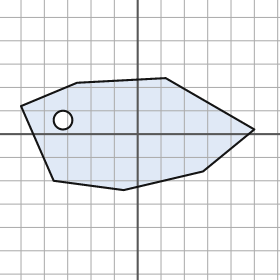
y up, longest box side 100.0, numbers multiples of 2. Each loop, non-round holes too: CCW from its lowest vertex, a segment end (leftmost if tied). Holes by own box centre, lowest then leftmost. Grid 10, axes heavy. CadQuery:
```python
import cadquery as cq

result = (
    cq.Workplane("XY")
    .moveTo(-6.0, -24.0)
    .lineTo(28.0, -16.0)
    .lineTo(50.0, 2.0)
    .lineTo(12.0, 24.0)
    .lineTo(-26.0, 22.0)
    .lineTo(-50.0, 12.0)
    .lineTo(-36.0, -20.0)
    .close()
    .moveTo(-32.0, 6.0)
    .circle(4.0)
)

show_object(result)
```